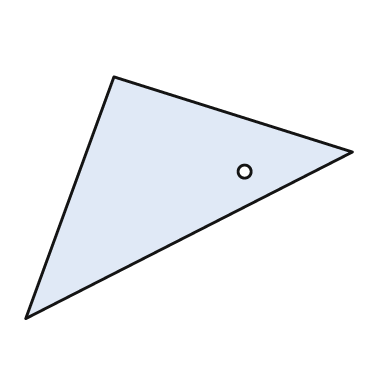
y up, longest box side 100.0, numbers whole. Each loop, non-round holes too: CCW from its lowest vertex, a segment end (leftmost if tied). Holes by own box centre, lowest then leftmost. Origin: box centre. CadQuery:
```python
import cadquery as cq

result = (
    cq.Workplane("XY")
    .moveTo(-50.0, -37.0)
    .lineTo(50.0, 14.0)
    .lineTo(-23.0, 37.0)
    .close()
    .moveTo(17.0, 8.0)
    .circle(2.0)
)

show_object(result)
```